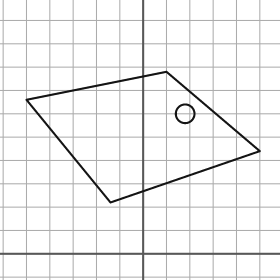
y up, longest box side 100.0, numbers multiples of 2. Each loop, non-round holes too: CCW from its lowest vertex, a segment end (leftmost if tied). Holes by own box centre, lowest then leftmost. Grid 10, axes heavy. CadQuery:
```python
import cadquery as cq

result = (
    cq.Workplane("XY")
    .moveTo(-14.0, 22.0)
    .lineTo(50.0, 44.0)
    .lineTo(10.0, 78.0)
    .lineTo(-50.0, 66.0)
    .close()
    .moveTo(18.0, 60.0)
    .circle(4.0)
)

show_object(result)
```